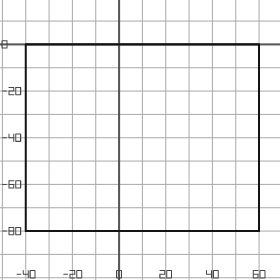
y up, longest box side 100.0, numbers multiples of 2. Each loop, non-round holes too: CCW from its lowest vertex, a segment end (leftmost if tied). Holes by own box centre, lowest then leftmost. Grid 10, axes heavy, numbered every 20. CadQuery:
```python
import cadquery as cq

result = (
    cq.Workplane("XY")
    .moveTo(-40.0, -80.0)
    .lineTo(60.0, -80.0)
    .lineTo(60.0, 0.0)
    .lineTo(-40.0, 0.0)
    .close()
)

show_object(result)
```